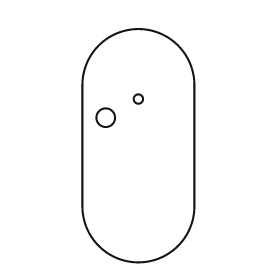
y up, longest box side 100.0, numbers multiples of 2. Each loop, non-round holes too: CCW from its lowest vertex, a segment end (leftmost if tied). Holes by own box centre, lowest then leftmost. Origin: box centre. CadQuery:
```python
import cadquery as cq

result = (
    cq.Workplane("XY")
    .moveTo(-24.0, -26.0)
    .threePointArc((0.0, -50.0), (24.0, -26.0))
    .lineTo(24.0, 26.0)
    .threePointArc((0.0, 50.0), (-24.0, 26.0))
    .close()
    .moveTo(-14.0, 12.0)
    .circle(4.0)
    .moveTo(0.0, 20.0)
    .circle(2.0)
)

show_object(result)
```